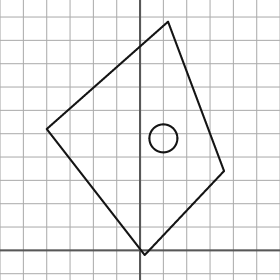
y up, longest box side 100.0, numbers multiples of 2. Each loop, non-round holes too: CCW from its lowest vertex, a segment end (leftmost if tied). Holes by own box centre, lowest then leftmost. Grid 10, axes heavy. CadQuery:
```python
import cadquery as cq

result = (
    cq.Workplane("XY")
    .moveTo(2.0, -2.0)
    .lineTo(36.0, 34.0)
    .lineTo(12.0, 98.0)
    .lineTo(-40.0, 52.0)
    .close()
    .moveTo(10.0, 48.0)
    .circle(6.0)
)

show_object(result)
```